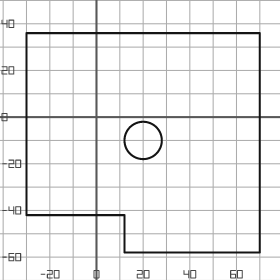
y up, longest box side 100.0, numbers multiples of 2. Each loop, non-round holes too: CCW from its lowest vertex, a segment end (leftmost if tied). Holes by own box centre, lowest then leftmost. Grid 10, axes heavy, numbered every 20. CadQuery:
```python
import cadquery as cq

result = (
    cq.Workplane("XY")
    .moveTo(12.0, -58.0)
    .lineTo(70.0, -58.0)
    .lineTo(70.0, 36.0)
    .lineTo(-30.0, 36.0)
    .lineTo(-30.0, -42.0)
    .lineTo(12.0, -42.0)
    .close()
    .moveTo(20.0, -10.0)
    .circle(8.0)
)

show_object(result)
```